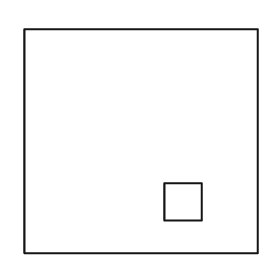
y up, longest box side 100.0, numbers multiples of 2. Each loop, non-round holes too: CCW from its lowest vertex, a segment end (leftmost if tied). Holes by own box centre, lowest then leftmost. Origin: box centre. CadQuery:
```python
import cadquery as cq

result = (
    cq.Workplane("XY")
    .moveTo(-50.0, -48.0)
    .lineTo(50.0, -48.0)
    .lineTo(50.0, 48.0)
    .lineTo(-50.0, 48.0)
    .close()
    .moveTo(10.0, -34.0)
    .lineTo(26.0, -34.0)
    .lineTo(26.0, -18.0)
    .lineTo(10.0, -18.0)
    .close()
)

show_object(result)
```